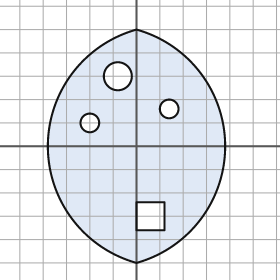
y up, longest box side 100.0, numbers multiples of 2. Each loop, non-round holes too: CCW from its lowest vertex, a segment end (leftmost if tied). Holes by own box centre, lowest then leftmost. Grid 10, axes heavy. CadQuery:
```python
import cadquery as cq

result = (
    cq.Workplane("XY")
    .moveTo(0.0, -50.0)
    .threePointArc((38.0, 0.0), (0.0, 50.0))
    .threePointArc((-38.0, 0.0), (0.0, -50.0))
    .close()
    .moveTo(0.0, -36.0)
    .lineTo(12.0, -36.0)
    .lineTo(12.0, -24.0)
    .lineTo(0.0, -24.0)
    .close()
    .moveTo(-20.0, 10.0)
    .circle(4.0)
    .moveTo(14.0, 16.0)
    .circle(4.0)
    .moveTo(-8.0, 30.0)
    .circle(6.0)
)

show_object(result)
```